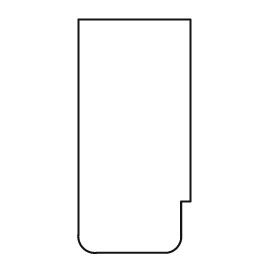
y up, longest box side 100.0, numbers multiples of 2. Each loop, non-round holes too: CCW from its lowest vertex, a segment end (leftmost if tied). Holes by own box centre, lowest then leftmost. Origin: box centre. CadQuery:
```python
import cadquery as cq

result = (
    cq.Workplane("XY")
    .moveTo(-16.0, -50.0)
    .lineTo(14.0, -50.0)
    .threePointArc((18.0, -48.0), (20.0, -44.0))
    .lineTo(20.0, -28.0)
    .lineTo(24.0, -28.0)
    .lineTo(24.0, 50.0)
    .lineTo(-24.0, 50.0)
    .lineTo(-24.0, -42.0)
    .threePointArc((-22.0, -48.0), (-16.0, -50.0))
    .close()
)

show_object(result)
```